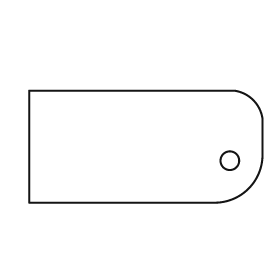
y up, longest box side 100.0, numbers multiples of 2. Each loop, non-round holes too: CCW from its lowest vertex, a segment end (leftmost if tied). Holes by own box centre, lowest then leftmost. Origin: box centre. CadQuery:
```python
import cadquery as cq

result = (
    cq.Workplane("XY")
    .moveTo(-50.0, -24.0)
    .lineTo(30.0, -24.0)
    .threePointArc((44.0, -18.0), (50.0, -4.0))
    .lineTo(50.0, 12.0)
    .threePointArc((46.0, 20.0), (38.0, 24.0))
    .lineTo(-50.0, 24.0)
    .close()
    .moveTo(36.0, -6.0)
    .circle(4.0)
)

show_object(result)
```